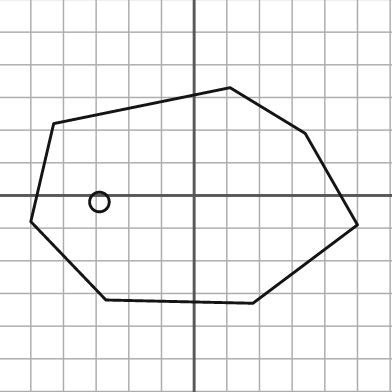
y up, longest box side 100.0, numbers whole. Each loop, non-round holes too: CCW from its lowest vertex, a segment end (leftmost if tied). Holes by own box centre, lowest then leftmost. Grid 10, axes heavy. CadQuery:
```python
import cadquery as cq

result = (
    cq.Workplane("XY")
    .moveTo(18.0, -33.0)
    .lineTo(50.0, -9.0)
    .lineTo(34.0, 19.0)
    .lineTo(11.0, 33.0)
    .lineTo(-43.0, 22.0)
    .lineTo(-50.0, -8.0)
    .lineTo(-27.0, -32.0)
    .close()
    .moveTo(-29.0, -2.0)
    .circle(3.0)
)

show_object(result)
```